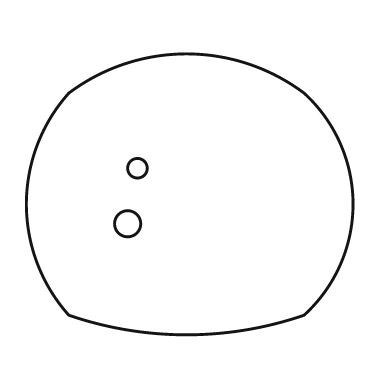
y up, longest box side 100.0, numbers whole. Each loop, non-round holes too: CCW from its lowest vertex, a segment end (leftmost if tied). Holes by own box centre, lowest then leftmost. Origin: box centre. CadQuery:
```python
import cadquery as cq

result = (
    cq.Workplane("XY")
    .moveTo(-37.0, -37.0)
    .threePointArc((-1.0, -43.0), (35.0, -37.0))
    .threePointArc((50.0, -3.0), (35.0, 31.0))
    .threePointArc((-1.0, 43.0), (-37.0, 31.0))
    .threePointArc((-50.0, -3.0), (-37.0, -37.0))
    .close()
    .moveTo(-19.0, -9.0)
    .circle(4.0)
    .moveTo(-16.0, 8.0)
    .circle(3.0)
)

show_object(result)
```